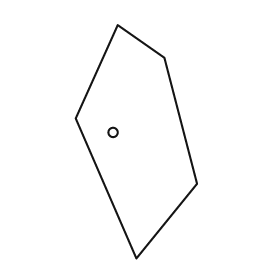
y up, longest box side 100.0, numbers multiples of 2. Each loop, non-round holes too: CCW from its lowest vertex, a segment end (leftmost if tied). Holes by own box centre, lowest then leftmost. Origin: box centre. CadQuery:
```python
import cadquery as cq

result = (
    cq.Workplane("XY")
    .moveTo(0.0, -50.0)
    .lineTo(26.0, -18.0)
    .lineTo(12.0, 36.0)
    .lineTo(-8.0, 50.0)
    .lineTo(-26.0, 10.0)
    .close()
    .moveTo(-10.0, 4.0)
    .circle(2.0)
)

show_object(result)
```